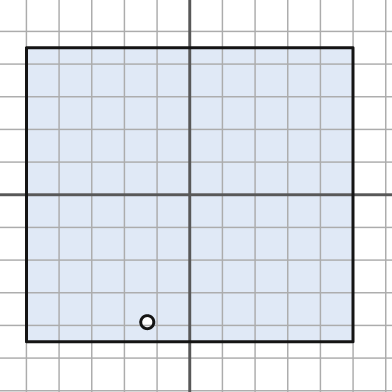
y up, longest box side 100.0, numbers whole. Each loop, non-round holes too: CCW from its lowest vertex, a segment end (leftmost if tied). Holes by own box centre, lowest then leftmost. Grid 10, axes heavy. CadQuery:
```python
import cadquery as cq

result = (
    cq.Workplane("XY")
    .moveTo(-50.0, -45.0)
    .lineTo(50.0, -45.0)
    .lineTo(50.0, 45.0)
    .lineTo(-50.0, 45.0)
    .close()
    .moveTo(-13.0, -39.0)
    .circle(2.0)
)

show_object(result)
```